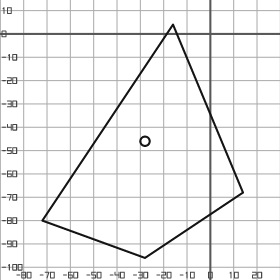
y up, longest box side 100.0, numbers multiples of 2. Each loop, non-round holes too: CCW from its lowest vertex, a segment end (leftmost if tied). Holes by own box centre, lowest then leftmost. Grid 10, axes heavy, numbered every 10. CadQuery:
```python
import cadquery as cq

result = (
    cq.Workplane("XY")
    .moveTo(-28.0, -96.0)
    .lineTo(14.0, -68.0)
    .lineTo(-16.0, 4.0)
    .lineTo(-72.0, -80.0)
    .close()
    .moveTo(-28.0, -46.0)
    .circle(2.0)
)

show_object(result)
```